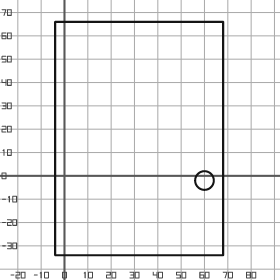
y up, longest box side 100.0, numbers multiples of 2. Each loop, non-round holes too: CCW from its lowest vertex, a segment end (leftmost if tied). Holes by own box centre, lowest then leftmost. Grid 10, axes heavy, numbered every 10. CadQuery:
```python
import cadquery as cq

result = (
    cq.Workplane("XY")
    .moveTo(-4.0, -34.0)
    .lineTo(68.0, -34.0)
    .lineTo(68.0, 66.0)
    .lineTo(-4.0, 66.0)
    .close()
    .moveTo(60.0, -2.0)
    .circle(4.0)
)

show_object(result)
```